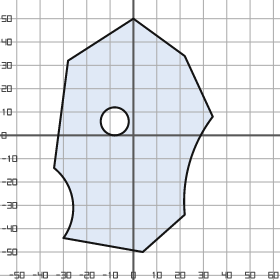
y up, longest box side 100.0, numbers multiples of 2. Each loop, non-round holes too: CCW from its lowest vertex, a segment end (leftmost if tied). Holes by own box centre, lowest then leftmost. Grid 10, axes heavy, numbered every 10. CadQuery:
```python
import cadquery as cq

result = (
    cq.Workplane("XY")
    .moveTo(4.0, -50.0)
    .lineTo(22.0, -34.0)
    .threePointArc((24.0, -12.0), (34.0, 8.0))
    .lineTo(22.0, 34.0)
    .lineTo(0.0, 50.0)
    .lineTo(-28.0, 32.0)
    .lineTo(-34.0, -14.0)
    .threePointArc((-26.0, -28.0), (-30.0, -44.0))
    .close()
    .moveTo(-8.0, 6.0)
    .circle(6.0)
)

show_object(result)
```